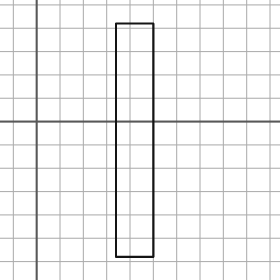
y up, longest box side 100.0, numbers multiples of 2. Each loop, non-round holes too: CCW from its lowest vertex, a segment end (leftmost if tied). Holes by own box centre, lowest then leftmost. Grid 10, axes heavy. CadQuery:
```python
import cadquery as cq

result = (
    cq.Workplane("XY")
    .moveTo(34.0, -58.0)
    .lineTo(50.0, -58.0)
    .lineTo(50.0, 42.0)
    .lineTo(34.0, 42.0)
    .close()
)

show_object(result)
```